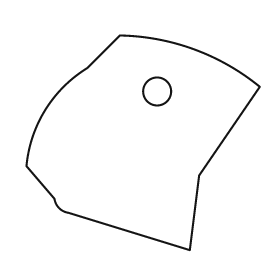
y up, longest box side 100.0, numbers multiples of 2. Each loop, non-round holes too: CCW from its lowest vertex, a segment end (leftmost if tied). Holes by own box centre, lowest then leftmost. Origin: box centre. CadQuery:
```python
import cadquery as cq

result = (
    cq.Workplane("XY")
    .moveTo(20.0, -46.0)
    .lineTo(24.0, -14.0)
    .lineTo(50.0, 24.0)
    .threePointArc((22.0, 40.0), (-10.0, 46.0))
    .lineTo(-24.0, 32.0)
    .threePointArc((-42.0, 14.0), (-50.0, -10.0))
    .lineTo(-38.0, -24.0)
    .threePointArc((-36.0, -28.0), (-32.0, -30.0))
    .close()
    .moveTo(6.0, 22.0)
    .circle(6.0)
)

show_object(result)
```